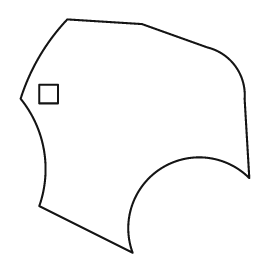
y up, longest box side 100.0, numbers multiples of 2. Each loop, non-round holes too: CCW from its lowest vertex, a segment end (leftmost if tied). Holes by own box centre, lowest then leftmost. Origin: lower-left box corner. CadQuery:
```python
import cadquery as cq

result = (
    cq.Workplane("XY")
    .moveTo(48.0, 0.0)
    .threePointArc((60.0, 36.0), (98.0, 32.0))
    .lineTo(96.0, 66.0)
    .threePointArc((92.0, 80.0), (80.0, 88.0))
    .lineTo(52.0, 98.0)
    .lineTo(20.0, 100.0)
    .threePointArc((8.0, 84.0), (0.0, 66.0))
    .threePointArc((10.0, 44.0), (8.0, 20.0))
    .close()
    .moveTo(8.0, 64.0)
    .lineTo(16.0, 64.0)
    .lineTo(16.0, 72.0)
    .lineTo(8.0, 72.0)
    .close()
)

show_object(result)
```